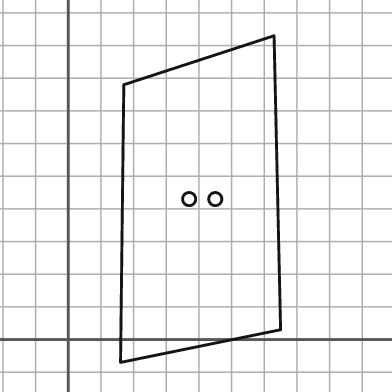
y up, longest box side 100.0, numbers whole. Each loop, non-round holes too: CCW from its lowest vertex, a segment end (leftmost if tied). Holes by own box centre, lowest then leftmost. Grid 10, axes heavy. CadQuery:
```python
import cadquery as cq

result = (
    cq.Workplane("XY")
    .moveTo(16.0, -7.0)
    .lineTo(65.0, 3.0)
    .lineTo(63.0, 93.0)
    .lineTo(17.0, 78.0)
    .close()
    .moveTo(37.0, 43.0)
    .circle(2.0)
    .moveTo(45.0, 43.0)
    .circle(2.0)
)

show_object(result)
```